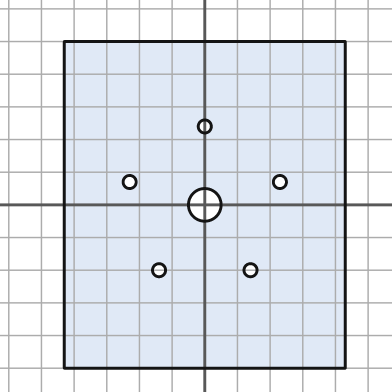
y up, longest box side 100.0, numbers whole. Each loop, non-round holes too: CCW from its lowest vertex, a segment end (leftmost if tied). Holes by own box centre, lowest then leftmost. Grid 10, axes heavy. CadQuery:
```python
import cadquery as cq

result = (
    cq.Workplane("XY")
    .moveTo(-43.0, -50.0)
    .lineTo(43.0, -50.0)
    .lineTo(43.0, 50.0)
    .lineTo(-43.0, 50.0)
    .close()
    .moveTo(-14.0, -20.0)
    .circle(2.0)
    .moveTo(14.0, -20.0)
    .circle(2.0)
    .moveTo(0.0, 0.0)
    .circle(5.0)
    .moveTo(-23.0, 7.0)
    .circle(2.0)
    .moveTo(23.0, 7.0)
    .circle(2.0)
    .moveTo(0.0, 24.0)
    .circle(2.0)
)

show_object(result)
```